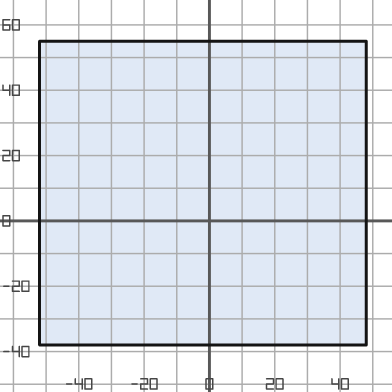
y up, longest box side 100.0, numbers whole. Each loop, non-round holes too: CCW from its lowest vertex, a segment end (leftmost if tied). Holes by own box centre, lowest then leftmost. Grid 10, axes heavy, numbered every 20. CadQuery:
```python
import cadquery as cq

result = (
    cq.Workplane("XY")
    .moveTo(-52.0, -38.0)
    .lineTo(48.0, -38.0)
    .lineTo(48.0, 55.0)
    .lineTo(-52.0, 55.0)
    .close()
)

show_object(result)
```